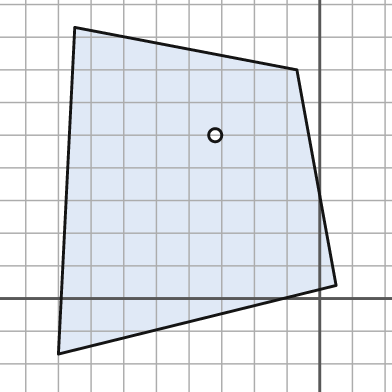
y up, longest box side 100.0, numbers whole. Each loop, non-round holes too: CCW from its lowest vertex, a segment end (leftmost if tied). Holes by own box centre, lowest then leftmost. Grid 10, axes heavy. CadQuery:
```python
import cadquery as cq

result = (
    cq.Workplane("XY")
    .moveTo(-80.0, -17.0)
    .lineTo(5.0, 4.0)
    .lineTo(-7.0, 70.0)
    .lineTo(-75.0, 83.0)
    .close()
    .moveTo(-32.0, 50.0)
    .circle(2.0)
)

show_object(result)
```